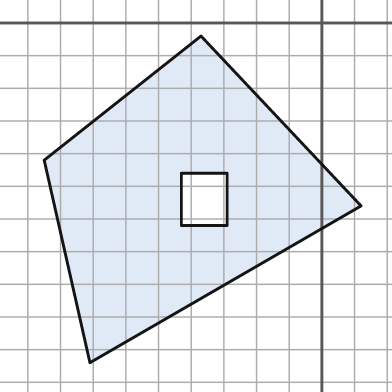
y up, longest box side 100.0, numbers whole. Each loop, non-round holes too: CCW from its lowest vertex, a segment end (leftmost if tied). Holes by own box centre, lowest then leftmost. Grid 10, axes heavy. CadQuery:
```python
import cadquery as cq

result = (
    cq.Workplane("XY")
    .moveTo(-71.0, -104.0)
    .lineTo(12.0, -56.0)
    .lineTo(-37.0, -4.0)
    .lineTo(-85.0, -42.0)
    .close()
    .moveTo(-43.0, -62.0)
    .lineTo(-29.0, -62.0)
    .lineTo(-29.0, -46.0)
    .lineTo(-43.0, -46.0)
    .close()
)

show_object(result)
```